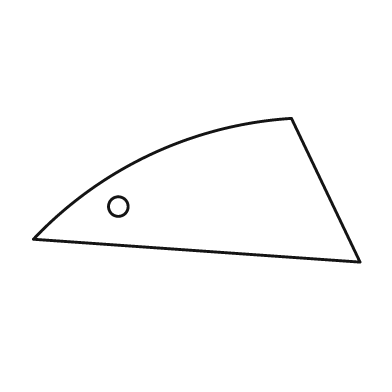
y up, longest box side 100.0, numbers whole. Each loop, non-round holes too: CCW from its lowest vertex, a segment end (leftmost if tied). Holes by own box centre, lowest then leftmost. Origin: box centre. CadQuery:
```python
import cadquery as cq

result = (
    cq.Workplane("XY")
    .moveTo(50.0, -22.0)
    .lineTo(29.0, 22.0)
    .threePointArc((-14.0, 11.0), (-50.0, -15.0))
    .close()
    .moveTo(-24.0, -5.0)
    .circle(3.0)
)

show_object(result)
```